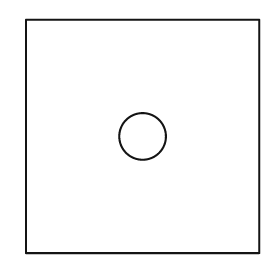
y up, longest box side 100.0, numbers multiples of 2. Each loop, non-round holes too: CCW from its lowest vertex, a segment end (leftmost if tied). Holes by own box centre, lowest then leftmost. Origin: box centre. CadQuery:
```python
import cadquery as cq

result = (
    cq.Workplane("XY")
    .moveTo(-50.0, -50.0)
    .lineTo(50.0, -50.0)
    .lineTo(50.0, 50.0)
    .lineTo(-50.0, 50.0)
    .close()
    .moveTo(0.0, 0.0)
    .circle(10.0)
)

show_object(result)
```